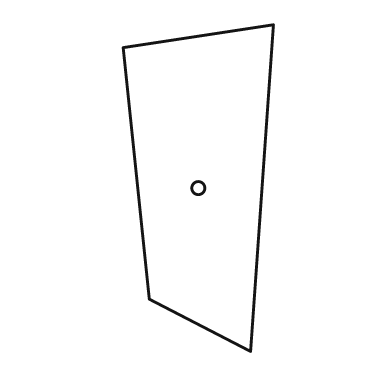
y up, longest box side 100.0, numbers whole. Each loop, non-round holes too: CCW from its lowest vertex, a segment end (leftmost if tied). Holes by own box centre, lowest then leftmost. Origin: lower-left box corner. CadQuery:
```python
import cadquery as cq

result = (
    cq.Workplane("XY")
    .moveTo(39.0, 0.0)
    .lineTo(46.0, 100.0)
    .lineTo(0.0, 93.0)
    .lineTo(8.0, 16.0)
    .close()
    .moveTo(23.0, 50.0)
    .circle(2.0)
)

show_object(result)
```